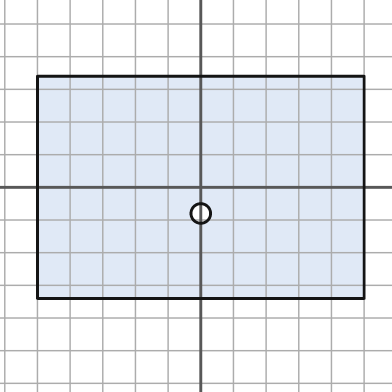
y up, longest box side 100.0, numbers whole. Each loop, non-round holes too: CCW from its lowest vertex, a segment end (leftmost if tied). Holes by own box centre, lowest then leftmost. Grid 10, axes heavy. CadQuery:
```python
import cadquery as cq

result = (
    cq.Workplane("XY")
    .moveTo(-50.0, -34.0)
    .lineTo(50.0, -34.0)
    .lineTo(50.0, 34.0)
    .lineTo(-50.0, 34.0)
    .close()
    .moveTo(0.0, -8.0)
    .circle(3.0)
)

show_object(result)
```